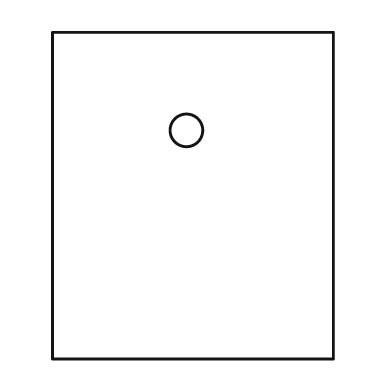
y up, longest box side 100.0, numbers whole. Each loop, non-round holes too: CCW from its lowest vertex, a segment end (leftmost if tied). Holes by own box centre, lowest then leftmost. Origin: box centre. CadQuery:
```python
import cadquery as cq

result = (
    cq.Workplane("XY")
    .moveTo(-43.0, -50.0)
    .lineTo(43.0, -50.0)
    .lineTo(43.0, 50.0)
    .lineTo(-43.0, 50.0)
    .close()
    .moveTo(-2.0, 20.0)
    .circle(5.0)
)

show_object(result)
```